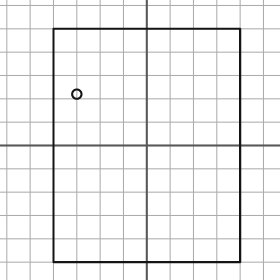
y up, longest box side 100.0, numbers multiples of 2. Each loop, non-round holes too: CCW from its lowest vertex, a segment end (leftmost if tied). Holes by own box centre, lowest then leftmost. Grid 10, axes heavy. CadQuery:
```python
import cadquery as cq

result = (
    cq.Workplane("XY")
    .moveTo(-40.0, -50.0)
    .lineTo(40.0, -50.0)
    .lineTo(40.0, 50.0)
    .lineTo(-40.0, 50.0)
    .close()
    .moveTo(-30.0, 22.0)
    .circle(2.0)
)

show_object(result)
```